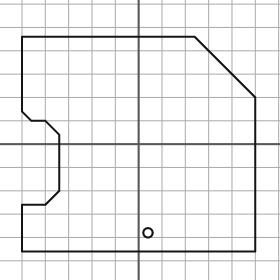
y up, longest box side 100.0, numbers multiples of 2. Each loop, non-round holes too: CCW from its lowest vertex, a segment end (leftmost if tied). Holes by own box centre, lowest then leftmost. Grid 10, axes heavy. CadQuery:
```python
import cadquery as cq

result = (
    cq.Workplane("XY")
    .moveTo(-50.0, -46.0)
    .lineTo(50.0, -46.0)
    .lineTo(50.0, 20.0)
    .lineTo(24.0, 46.0)
    .lineTo(-50.0, 46.0)
    .lineTo(-50.0, 14.0)
    .lineTo(-46.0, 10.0)
    .lineTo(-40.0, 10.0)
    .lineTo(-34.0, 4.0)
    .lineTo(-34.0, -20.0)
    .lineTo(-40.0, -26.0)
    .lineTo(-50.0, -26.0)
    .close()
    .moveTo(4.0, -38.0)
    .circle(2.0)
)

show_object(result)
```